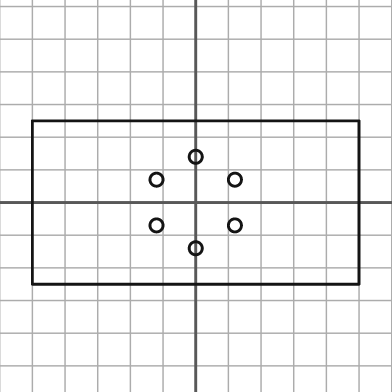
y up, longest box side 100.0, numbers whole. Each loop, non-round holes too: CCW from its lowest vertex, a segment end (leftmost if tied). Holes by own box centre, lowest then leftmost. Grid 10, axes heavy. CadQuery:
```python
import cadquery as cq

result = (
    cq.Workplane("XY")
    .moveTo(-50.0, -25.0)
    .lineTo(50.0, -25.0)
    .lineTo(50.0, 25.0)
    .lineTo(-50.0, 25.0)
    .close()
    .moveTo(0.0, -14.0)
    .circle(2.0)
    .moveTo(-12.0, -7.0)
    .circle(2.0)
    .moveTo(12.0, -7.0)
    .circle(2.0)
    .moveTo(-12.0, 7.0)
    .circle(2.0)
    .moveTo(12.0, 7.0)
    .circle(2.0)
    .moveTo(0.0, 14.0)
    .circle(2.0)
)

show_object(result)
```